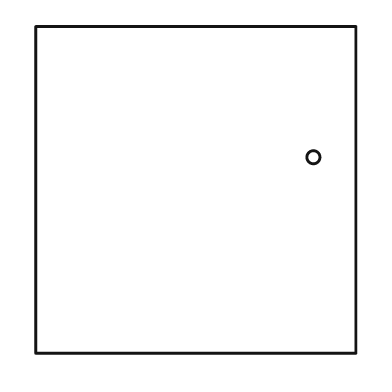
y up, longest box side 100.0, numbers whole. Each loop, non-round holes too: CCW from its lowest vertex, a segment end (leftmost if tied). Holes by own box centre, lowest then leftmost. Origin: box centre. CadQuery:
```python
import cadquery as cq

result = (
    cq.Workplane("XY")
    .moveTo(-49.0, -50.0)
    .lineTo(49.0, -50.0)
    .lineTo(49.0, 50.0)
    .lineTo(-49.0, 50.0)
    .close()
    .moveTo(36.0, 10.0)
    .circle(2.0)
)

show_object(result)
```